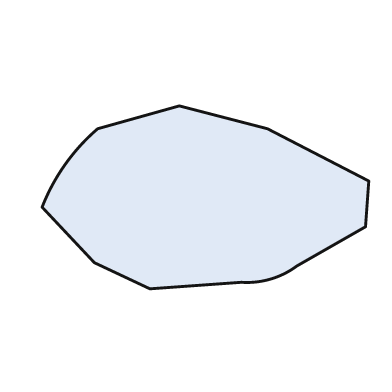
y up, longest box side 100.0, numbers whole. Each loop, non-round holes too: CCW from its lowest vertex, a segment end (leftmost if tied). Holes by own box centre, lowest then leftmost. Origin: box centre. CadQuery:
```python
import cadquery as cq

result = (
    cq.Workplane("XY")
    .moveTo(-17.0, -28.0)
    .lineTo(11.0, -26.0)
    .threePointArc((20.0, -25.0), (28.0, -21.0))
    .lineTo(49.0, -9.0)
    .lineTo(50.0, 5.0)
    .lineTo(19.0, 21.0)
    .lineTo(-8.0, 28.0)
    .lineTo(-33.0, 21.0)
    .threePointArc((-43.0, 10.0), (-50.0, -3.0))
    .lineTo(-34.0, -20.0)
    .close()
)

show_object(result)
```